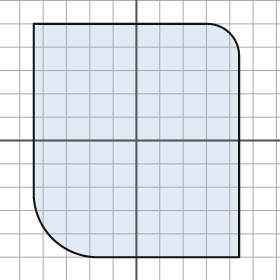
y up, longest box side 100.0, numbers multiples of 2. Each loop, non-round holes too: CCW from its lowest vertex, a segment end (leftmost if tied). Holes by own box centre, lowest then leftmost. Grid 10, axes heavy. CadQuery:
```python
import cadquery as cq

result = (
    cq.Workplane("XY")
    .moveTo(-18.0, -50.0)
    .lineTo(44.0, -50.0)
    .lineTo(44.0, 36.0)
    .threePointArc((40.0, 46.0), (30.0, 50.0))
    .lineTo(-44.0, 50.0)
    .lineTo(-44.0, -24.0)
    .threePointArc((-36.0, -42.0), (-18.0, -50.0))
    .close()
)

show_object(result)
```